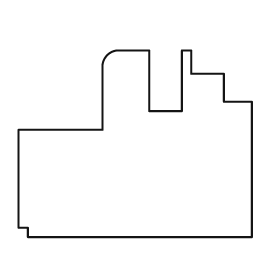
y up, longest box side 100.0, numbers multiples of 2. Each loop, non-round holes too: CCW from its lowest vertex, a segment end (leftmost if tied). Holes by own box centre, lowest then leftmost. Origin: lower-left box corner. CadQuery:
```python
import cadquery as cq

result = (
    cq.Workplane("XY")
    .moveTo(4.0, 0.0)
    .lineTo(100.0, 0.0)
    .lineTo(100.0, 58.0)
    .lineTo(88.0, 58.0)
    .lineTo(88.0, 70.0)
    .lineTo(74.0, 70.0)
    .lineTo(74.0, 80.0)
    .lineTo(70.0, 80.0)
    .lineTo(70.0, 54.0)
    .lineTo(56.0, 54.0)
    .lineTo(56.0, 80.0)
    .lineTo(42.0, 80.0)
    .threePointArc((38.0, 78.0), (36.0, 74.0))
    .lineTo(36.0, 46.0)
    .lineTo(0.0, 46.0)
    .lineTo(0.0, 4.0)
    .lineTo(4.0, 4.0)
    .close()
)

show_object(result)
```